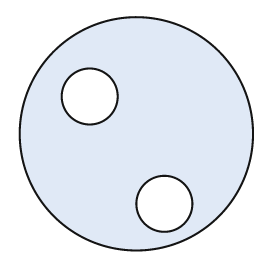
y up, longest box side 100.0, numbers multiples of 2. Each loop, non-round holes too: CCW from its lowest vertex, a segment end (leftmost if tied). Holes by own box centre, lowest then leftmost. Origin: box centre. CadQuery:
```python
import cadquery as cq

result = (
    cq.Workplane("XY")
    .moveTo(0.0, 0.0)
    .circle(50.0)
    .moveTo(12.0, -30.0)
    .circle(12.0)
    .moveTo(-20.0, 16.0)
    .circle(12.0)
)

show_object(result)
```